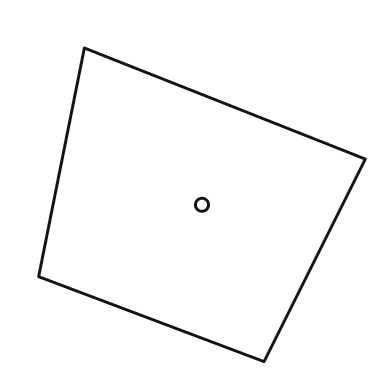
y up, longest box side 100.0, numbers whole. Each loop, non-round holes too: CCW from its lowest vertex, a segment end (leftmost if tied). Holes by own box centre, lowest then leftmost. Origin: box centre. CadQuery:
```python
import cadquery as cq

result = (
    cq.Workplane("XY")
    .moveTo(19.0, -48.0)
    .lineTo(50.0, 14.0)
    .lineTo(-36.0, 48.0)
    .lineTo(-50.0, -22.0)
    .close()
    .moveTo(0.0, 0.0)
    .circle(2.0)
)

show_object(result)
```